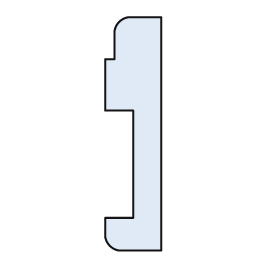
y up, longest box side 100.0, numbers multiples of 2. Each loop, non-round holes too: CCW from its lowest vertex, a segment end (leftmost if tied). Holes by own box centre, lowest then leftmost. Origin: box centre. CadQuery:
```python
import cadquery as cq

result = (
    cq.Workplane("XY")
    .moveTo(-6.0, -50.0)
    .lineTo(12.0, -50.0)
    .lineTo(12.0, 50.0)
    .lineTo(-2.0, 50.0)
    .threePointArc((-6.0, 48.0), (-8.0, 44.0))
    .lineTo(-8.0, 32.0)
    .lineTo(-12.0, 32.0)
    .lineTo(-12.0, 10.0)
    .lineTo(0.0, 10.0)
    .lineTo(0.0, -36.0)
    .lineTo(-12.0, -36.0)
    .lineTo(-12.0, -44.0)
    .threePointArc((-10.0, -48.0), (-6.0, -50.0))
    .close()
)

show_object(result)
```